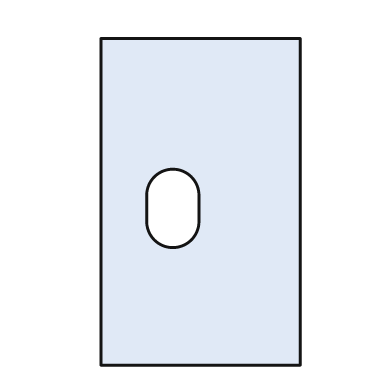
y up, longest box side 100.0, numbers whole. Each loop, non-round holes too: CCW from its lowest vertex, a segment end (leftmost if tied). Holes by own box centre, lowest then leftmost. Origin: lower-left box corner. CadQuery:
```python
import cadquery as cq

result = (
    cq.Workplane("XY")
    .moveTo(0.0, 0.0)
    .lineTo(61.0, 0.0)
    .lineTo(61.0, 100.0)
    .lineTo(0.0, 100.0)
    .close()
    .moveTo(14.0, 44.0)
    .threePointArc((22.0, 36.0), (30.0, 44.0))
    .lineTo(30.0, 52.0)
    .threePointArc((22.0, 60.0), (14.0, 52.0))
    .close()
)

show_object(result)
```